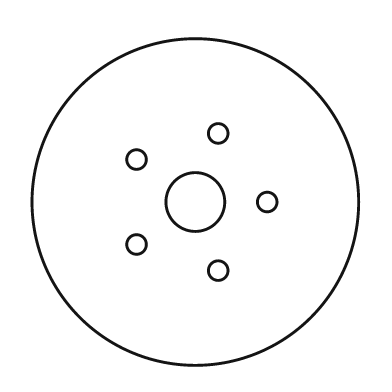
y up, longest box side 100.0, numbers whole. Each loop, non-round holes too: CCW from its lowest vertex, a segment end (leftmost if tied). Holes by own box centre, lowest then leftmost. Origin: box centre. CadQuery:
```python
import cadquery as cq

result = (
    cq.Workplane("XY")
    .moveTo(0.0, 0.0)
    .circle(50.0)
    .moveTo(7.0, -21.0)
    .circle(3.0)
    .moveTo(-18.0, -13.0)
    .circle(3.0)
    .moveTo(0.0, 0.0)
    .circle(9.0)
    .moveTo(22.0, 0.0)
    .circle(3.0)
    .moveTo(-18.0, 13.0)
    .circle(3.0)
    .moveTo(7.0, 21.0)
    .circle(3.0)
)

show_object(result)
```